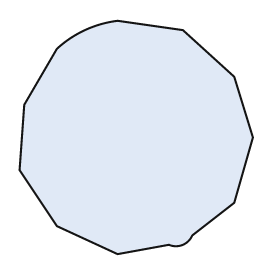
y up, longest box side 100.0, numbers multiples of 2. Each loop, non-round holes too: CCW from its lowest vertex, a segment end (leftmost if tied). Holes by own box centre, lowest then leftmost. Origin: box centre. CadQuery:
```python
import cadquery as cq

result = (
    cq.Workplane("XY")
    .moveTo(-8.0, -50.0)
    .lineTo(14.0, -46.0)
    .threePointArc((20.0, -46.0), (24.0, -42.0))
    .lineTo(42.0, -28.0)
    .lineTo(50.0, 0.0)
    .lineTo(42.0, 26.0)
    .lineTo(20.0, 46.0)
    .lineTo(-8.0, 50.0)
    .threePointArc((-22.0, 46.0), (-34.0, 38.0))
    .lineTo(-48.0, 14.0)
    .lineTo(-50.0, -14.0)
    .lineTo(-34.0, -38.0)
    .close()
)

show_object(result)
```